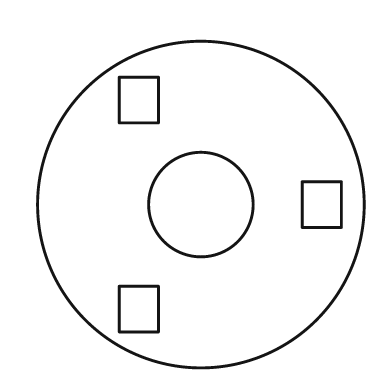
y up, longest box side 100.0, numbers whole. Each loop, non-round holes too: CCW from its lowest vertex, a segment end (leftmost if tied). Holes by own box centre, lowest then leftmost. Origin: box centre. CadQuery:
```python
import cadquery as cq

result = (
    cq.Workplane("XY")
    .moveTo(0.0, 0.0)
    .circle(50.0)
    .moveTo(-25.0, -39.0)
    .lineTo(-13.0, -39.0)
    .lineTo(-13.0, -25.0)
    .lineTo(-25.0, -25.0)
    .close()
    .moveTo(0.0, 0.0)
    .circle(16.0)
    .moveTo(31.0, -7.0)
    .lineTo(43.0, -7.0)
    .lineTo(43.0, 7.0)
    .lineTo(31.0, 7.0)
    .close()
    .moveTo(-25.0, 25.0)
    .lineTo(-13.0, 25.0)
    .lineTo(-13.0, 39.0)
    .lineTo(-25.0, 39.0)
    .close()
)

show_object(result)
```